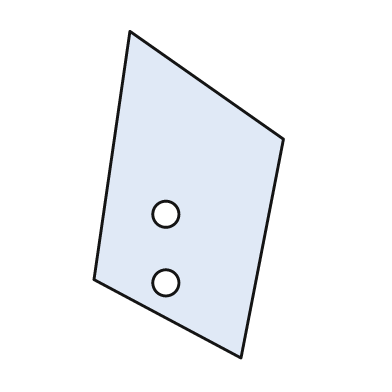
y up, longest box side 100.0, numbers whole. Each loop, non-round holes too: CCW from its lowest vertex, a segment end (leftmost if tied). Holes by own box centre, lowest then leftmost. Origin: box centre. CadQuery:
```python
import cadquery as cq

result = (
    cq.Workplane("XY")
    .moveTo(16.0, -50.0)
    .lineTo(29.0, 17.0)
    .lineTo(-18.0, 50.0)
    .lineTo(-29.0, -26.0)
    .close()
    .moveTo(-7.0, -27.0)
    .circle(4.0)
    .moveTo(-7.0, -6.0)
    .circle(4.0)
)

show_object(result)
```